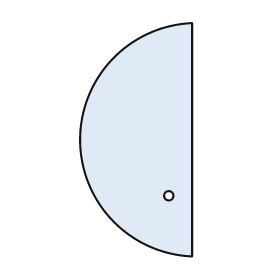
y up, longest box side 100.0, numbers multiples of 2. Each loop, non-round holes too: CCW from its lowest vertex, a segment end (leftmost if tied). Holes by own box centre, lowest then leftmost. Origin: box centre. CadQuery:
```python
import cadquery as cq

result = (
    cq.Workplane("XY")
    .moveTo(24.0, -50.0)
    .lineTo(24.0, 50.0)
    .threePointArc((-24.0, 0.0), (24.0, -50.0))
    .close()
    .moveTo(14.0, -24.0)
    .circle(2.0)
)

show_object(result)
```